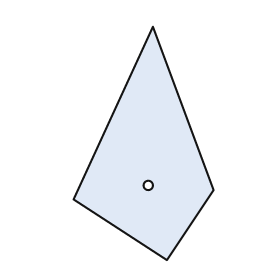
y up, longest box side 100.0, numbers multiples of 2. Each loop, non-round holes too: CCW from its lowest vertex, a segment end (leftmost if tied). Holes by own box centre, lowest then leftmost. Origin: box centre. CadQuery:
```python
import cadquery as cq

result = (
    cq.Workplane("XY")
    .moveTo(10.0, -50.0)
    .lineTo(30.0, -20.0)
    .lineTo(4.0, 50.0)
    .lineTo(-30.0, -24.0)
    .close()
    .moveTo(2.0, -18.0)
    .circle(2.0)
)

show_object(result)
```